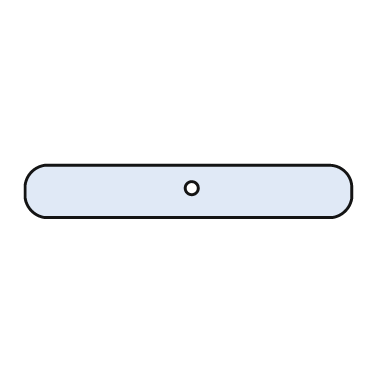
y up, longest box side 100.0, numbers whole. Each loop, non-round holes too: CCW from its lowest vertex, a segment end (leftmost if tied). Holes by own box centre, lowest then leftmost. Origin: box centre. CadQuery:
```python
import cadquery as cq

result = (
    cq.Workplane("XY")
    .moveTo(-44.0, -8.0)
    .lineTo(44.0, -8.0)
    .threePointArc((48.0, -6.0), (50.0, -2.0))
    .lineTo(50.0, 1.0)
    .threePointArc((48.0, 6.0), (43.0, 8.0))
    .lineTo(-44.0, 8.0)
    .threePointArc((-48.0, 6.0), (-50.0, 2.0))
    .lineTo(-50.0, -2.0)
    .threePointArc((-48.0, -6.0), (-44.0, -8.0))
    .close()
    .moveTo(1.0, 1.0)
    .circle(2.0)
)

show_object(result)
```